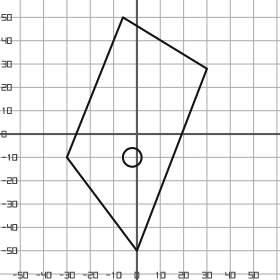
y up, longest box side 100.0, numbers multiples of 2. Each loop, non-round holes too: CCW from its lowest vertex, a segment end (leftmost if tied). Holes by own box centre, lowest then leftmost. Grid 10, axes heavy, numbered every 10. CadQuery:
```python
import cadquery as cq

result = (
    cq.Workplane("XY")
    .moveTo(0.0, -50.0)
    .lineTo(30.0, 28.0)
    .lineTo(-6.0, 50.0)
    .lineTo(-30.0, -10.0)
    .close()
    .moveTo(-2.0, -10.0)
    .circle(4.0)
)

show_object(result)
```